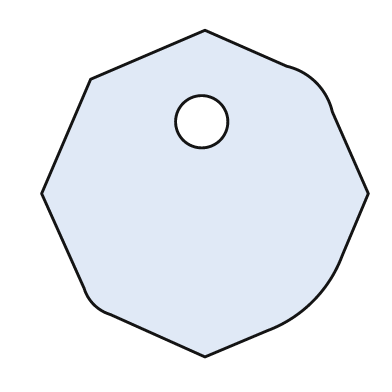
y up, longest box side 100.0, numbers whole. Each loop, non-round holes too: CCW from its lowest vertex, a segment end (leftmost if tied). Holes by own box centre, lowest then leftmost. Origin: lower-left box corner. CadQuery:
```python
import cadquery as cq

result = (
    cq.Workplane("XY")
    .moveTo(50.0, 0.0)
    .lineTo(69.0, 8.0)
    .threePointArc((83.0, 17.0), (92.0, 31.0))
    .lineTo(100.0, 50.0)
    .lineTo(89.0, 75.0)
    .threePointArc((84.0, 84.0), (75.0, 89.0))
    .lineTo(50.0, 100.0)
    .lineTo(15.0, 85.0)
    .lineTo(0.0, 50.0)
    .lineTo(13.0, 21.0)
    .threePointArc((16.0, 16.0), (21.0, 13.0))
    .close()
    .moveTo(49.0, 72.0)
    .circle(8.0)
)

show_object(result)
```